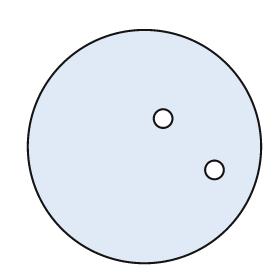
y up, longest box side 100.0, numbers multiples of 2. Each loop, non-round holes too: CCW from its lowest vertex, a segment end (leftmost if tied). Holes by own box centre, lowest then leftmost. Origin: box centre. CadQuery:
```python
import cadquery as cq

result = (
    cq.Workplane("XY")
    .moveTo(0.0, 0.0)
    .circle(50.0)
    .moveTo(30.0, -10.0)
    .circle(4.0)
    .moveTo(8.0, 12.0)
    .circle(4.0)
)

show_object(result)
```